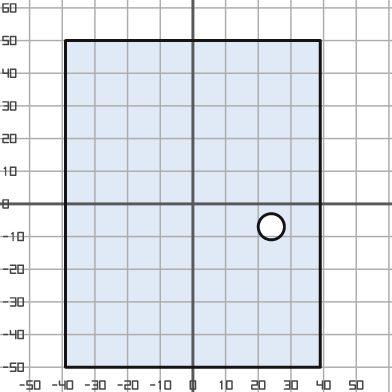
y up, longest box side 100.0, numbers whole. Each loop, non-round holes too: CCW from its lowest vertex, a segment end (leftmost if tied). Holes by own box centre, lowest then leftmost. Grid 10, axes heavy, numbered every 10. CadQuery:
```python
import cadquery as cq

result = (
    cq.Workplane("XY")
    .moveTo(-39.0, -50.0)
    .lineTo(39.0, -50.0)
    .lineTo(39.0, 50.0)
    .lineTo(-39.0, 50.0)
    .close()
    .moveTo(24.0, -7.0)
    .circle(4.0)
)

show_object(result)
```